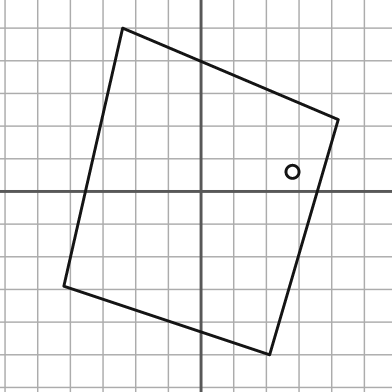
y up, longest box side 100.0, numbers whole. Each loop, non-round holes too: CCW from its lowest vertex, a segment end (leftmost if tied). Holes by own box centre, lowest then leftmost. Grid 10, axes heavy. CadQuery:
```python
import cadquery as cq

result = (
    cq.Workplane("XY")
    .moveTo(21.0, -50.0)
    .lineTo(42.0, 22.0)
    .lineTo(-24.0, 50.0)
    .lineTo(-42.0, -29.0)
    .close()
    .moveTo(28.0, 6.0)
    .circle(2.0)
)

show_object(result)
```